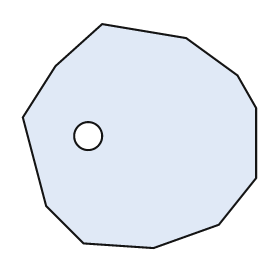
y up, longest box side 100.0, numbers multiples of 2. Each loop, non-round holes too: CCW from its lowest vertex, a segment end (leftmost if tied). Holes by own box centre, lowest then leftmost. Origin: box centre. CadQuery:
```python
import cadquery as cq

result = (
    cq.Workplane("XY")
    .moveTo(6.0, -48.0)
    .lineTo(34.0, -38.0)
    .lineTo(50.0, -18.0)
    .lineTo(50.0, 12.0)
    .lineTo(42.0, 26.0)
    .lineTo(20.0, 42.0)
    .lineTo(-16.0, 48.0)
    .lineTo(-36.0, 30.0)
    .lineTo(-50.0, 8.0)
    .lineTo(-40.0, -30.0)
    .lineTo(-24.0, -46.0)
    .close()
    .moveTo(-22.0, 0.0)
    .circle(6.0)
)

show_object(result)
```